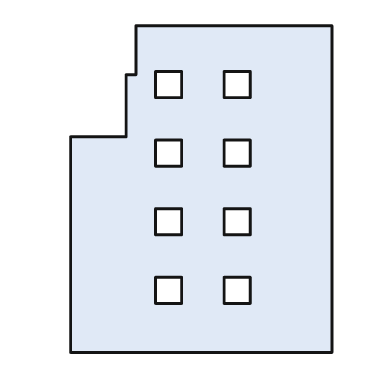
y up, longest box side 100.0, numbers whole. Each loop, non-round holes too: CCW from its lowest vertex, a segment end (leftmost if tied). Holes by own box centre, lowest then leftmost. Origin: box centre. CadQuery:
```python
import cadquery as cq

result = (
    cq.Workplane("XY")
    .moveTo(-40.0, -50.0)
    .lineTo(40.0, -50.0)
    .lineTo(40.0, 50.0)
    .lineTo(-20.0, 50.0)
    .lineTo(-20.0, 35.0)
    .lineTo(-23.0, 35.0)
    .lineTo(-23.0, 16.0)
    .lineTo(-40.0, 16.0)
    .close()
    .moveTo(-14.0, -35.0)
    .lineTo(-6.0, -35.0)
    .lineTo(-6.0, -27.0)
    .lineTo(-14.0, -27.0)
    .close()
    .moveTo(7.0, -35.0)
    .lineTo(15.0, -35.0)
    .lineTo(15.0, -27.0)
    .lineTo(7.0, -27.0)
    .close()
    .moveTo(-14.0, -14.0)
    .lineTo(-6.0, -14.0)
    .lineTo(-6.0, -6.0)
    .lineTo(-14.0, -6.0)
    .close()
    .moveTo(7.0, -14.0)
    .lineTo(15.0, -14.0)
    .lineTo(15.0, -6.0)
    .lineTo(7.0, -6.0)
    .close()
    .moveTo(-14.0, 7.0)
    .lineTo(-6.0, 7.0)
    .lineTo(-6.0, 15.0)
    .lineTo(-14.0, 15.0)
    .close()
    .moveTo(7.0, 7.0)
    .lineTo(15.0, 7.0)
    .lineTo(15.0, 15.0)
    .lineTo(7.0, 15.0)
    .close()
    .moveTo(-14.0, 28.0)
    .lineTo(-6.0, 28.0)
    .lineTo(-6.0, 36.0)
    .lineTo(-14.0, 36.0)
    .close()
    .moveTo(7.0, 28.0)
    .lineTo(15.0, 28.0)
    .lineTo(15.0, 36.0)
    .lineTo(7.0, 36.0)
    .close()
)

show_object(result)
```